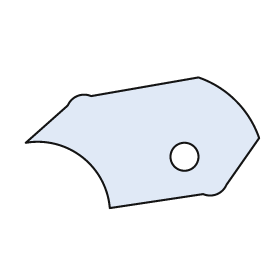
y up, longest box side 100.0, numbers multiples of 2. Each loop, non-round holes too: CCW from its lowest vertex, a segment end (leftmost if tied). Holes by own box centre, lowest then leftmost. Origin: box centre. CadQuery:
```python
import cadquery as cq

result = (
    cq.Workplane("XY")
    .moveTo(-14.0, -28.0)
    .lineTo(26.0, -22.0)
    .threePointArc((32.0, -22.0), (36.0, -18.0))
    .lineTo(50.0, 2.0)
    .threePointArc((40.0, 18.0), (24.0, 28.0))
    .lineTo(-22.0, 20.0)
    .threePointArc((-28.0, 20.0), (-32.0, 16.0))
    .lineTo(-50.0, 0.0)
    .threePointArc((-26.0, -6.0), (-14.0, -28.0))
    .close()
    .moveTo(18.0, -6.0)
    .circle(6.0)
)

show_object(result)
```